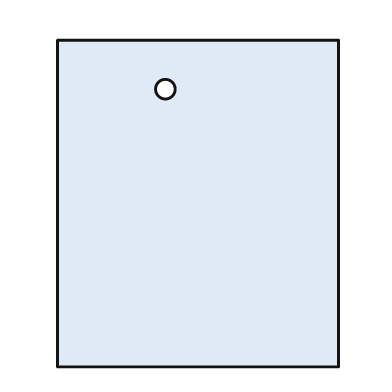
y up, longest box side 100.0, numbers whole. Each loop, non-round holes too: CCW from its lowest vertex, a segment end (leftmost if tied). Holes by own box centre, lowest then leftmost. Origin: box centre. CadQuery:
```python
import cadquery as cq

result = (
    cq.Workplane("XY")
    .moveTo(-43.0, -50.0)
    .lineTo(43.0, -50.0)
    .lineTo(43.0, 50.0)
    .lineTo(-43.0, 50.0)
    .close()
    .moveTo(-10.0, 35.0)
    .circle(3.0)
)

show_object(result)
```